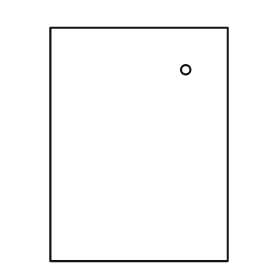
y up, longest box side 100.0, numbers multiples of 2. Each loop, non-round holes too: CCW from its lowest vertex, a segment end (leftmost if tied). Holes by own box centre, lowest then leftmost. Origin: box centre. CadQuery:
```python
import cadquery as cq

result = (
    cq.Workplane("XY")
    .moveTo(-38.0, -50.0)
    .lineTo(38.0, -50.0)
    .lineTo(38.0, 50.0)
    .lineTo(-38.0, 50.0)
    .close()
    .moveTo(20.0, 32.0)
    .circle(2.0)
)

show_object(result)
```